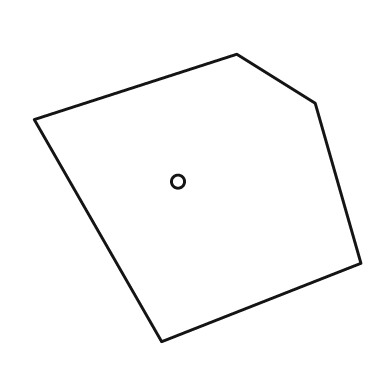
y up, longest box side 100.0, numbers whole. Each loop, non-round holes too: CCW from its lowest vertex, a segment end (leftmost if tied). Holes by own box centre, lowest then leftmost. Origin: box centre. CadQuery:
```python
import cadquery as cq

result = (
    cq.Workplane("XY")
    .moveTo(-11.0, -44.0)
    .lineTo(50.0, -20.0)
    .lineTo(36.0, 29.0)
    .lineTo(12.0, 44.0)
    .lineTo(-50.0, 24.0)
    .close()
    .moveTo(-6.0, 5.0)
    .circle(2.0)
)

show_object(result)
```